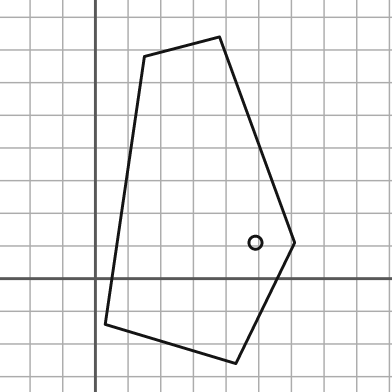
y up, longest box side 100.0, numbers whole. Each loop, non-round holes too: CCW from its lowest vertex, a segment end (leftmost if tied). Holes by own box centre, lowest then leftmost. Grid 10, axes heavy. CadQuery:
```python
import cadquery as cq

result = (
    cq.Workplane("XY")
    .moveTo(43.0, -26.0)
    .lineTo(61.0, 11.0)
    .lineTo(38.0, 74.0)
    .lineTo(15.0, 68.0)
    .lineTo(3.0, -14.0)
    .close()
    .moveTo(49.0, 11.0)
    .circle(2.0)
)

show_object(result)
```